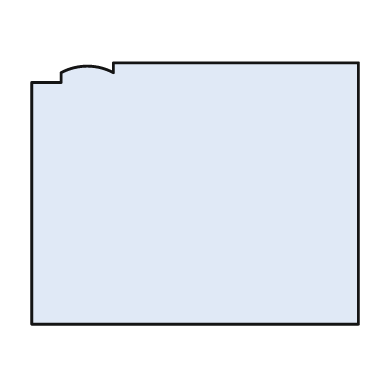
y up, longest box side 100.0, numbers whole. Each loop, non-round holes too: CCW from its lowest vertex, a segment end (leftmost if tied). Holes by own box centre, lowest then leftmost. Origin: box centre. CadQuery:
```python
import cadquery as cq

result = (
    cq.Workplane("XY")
    .moveTo(-50.0, -40.0)
    .lineTo(50.0, -40.0)
    .lineTo(50.0, 40.0)
    .lineTo(-25.0, 40.0)
    .lineTo(-25.0, 37.0)
    .threePointArc((-33.0, 39.0), (-41.0, 37.0))
    .lineTo(-41.0, 34.0)
    .lineTo(-50.0, 34.0)
    .close()
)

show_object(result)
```